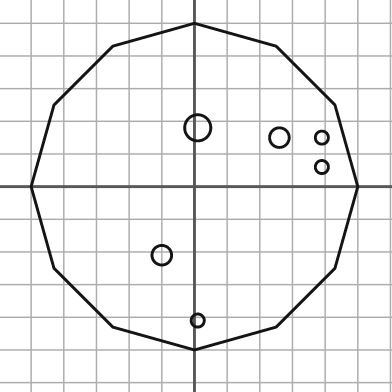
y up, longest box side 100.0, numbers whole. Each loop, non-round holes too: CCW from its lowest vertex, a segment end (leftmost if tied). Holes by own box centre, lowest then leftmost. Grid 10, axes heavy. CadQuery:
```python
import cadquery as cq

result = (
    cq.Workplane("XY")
    .moveTo(0.0, -50.0)
    .lineTo(25.0, -43.0)
    .lineTo(43.0, -25.0)
    .lineTo(50.0, 0.0)
    .lineTo(43.0, 25.0)
    .lineTo(25.0, 43.0)
    .lineTo(0.0, 50.0)
    .lineTo(-25.0, 43.0)
    .lineTo(-43.0, 25.0)
    .lineTo(-50.0, 0.0)
    .lineTo(-43.0, -25.0)
    .lineTo(-25.0, -43.0)
    .close()
    .moveTo(1.0, -41.0)
    .circle(2.0)
    .moveTo(-10.0, -21.0)
    .circle(3.0)
    .moveTo(39.0, 6.0)
    .circle(2.0)
    .moveTo(26.0, 15.0)
    .circle(3.0)
    .moveTo(39.0, 15.0)
    .circle(2.0)
    .moveTo(1.0, 18.0)
    .circle(4.0)
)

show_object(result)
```